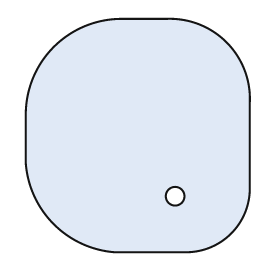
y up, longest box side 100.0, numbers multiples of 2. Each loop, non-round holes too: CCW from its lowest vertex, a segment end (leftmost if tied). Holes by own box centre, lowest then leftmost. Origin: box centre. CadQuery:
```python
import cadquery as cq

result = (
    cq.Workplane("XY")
    .moveTo(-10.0, -50.0)
    .lineTo(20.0, -50.0)
    .threePointArc((40.0, -42.0), (48.0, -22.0))
    .lineTo(48.0, 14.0)
    .threePointArc((38.0, 40.0), (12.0, 50.0))
    .lineTo(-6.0, 50.0)
    .threePointArc((-36.0, 38.0), (-48.0, 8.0))
    .lineTo(-48.0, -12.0)
    .threePointArc((-36.0, -38.0), (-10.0, -50.0))
    .close()
    .moveTo(16.0, -26.0)
    .circle(4.0)
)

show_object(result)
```